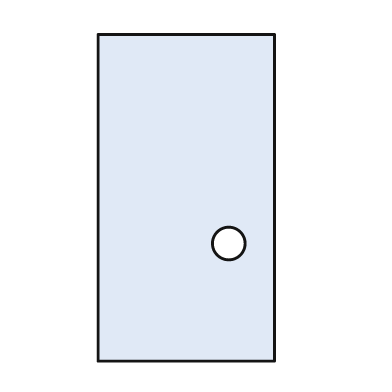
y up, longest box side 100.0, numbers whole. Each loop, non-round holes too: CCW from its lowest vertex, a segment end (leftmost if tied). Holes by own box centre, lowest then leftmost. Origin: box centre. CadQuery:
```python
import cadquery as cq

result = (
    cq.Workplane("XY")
    .moveTo(-27.0, -50.0)
    .lineTo(27.0, -50.0)
    .lineTo(27.0, 50.0)
    .lineTo(-27.0, 50.0)
    .close()
    .moveTo(13.0, -14.0)
    .circle(5.0)
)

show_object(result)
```